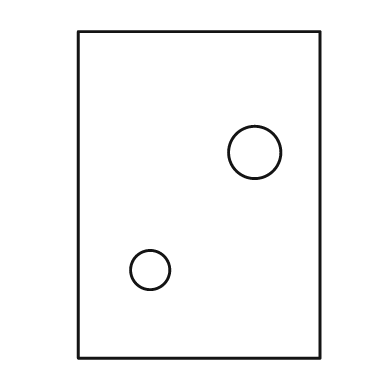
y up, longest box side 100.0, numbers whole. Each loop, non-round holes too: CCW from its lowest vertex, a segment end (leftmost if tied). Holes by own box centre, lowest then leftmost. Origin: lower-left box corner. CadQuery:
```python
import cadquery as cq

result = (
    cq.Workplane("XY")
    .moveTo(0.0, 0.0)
    .lineTo(74.0, 0.0)
    .lineTo(74.0, 100.0)
    .lineTo(0.0, 100.0)
    .close()
    .moveTo(22.0, 27.0)
    .circle(6.0)
    .moveTo(54.0, 63.0)
    .circle(8.0)
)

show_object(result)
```